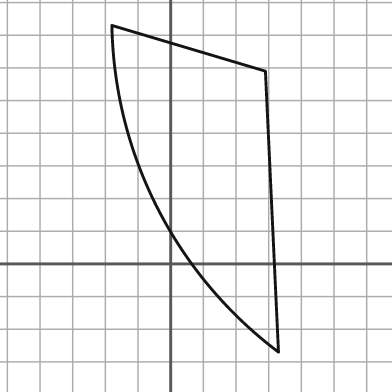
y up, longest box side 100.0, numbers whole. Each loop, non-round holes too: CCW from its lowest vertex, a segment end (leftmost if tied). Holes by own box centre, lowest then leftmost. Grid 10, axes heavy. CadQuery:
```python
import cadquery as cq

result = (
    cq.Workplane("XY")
    .moveTo(33.0, -27.0)
    .lineTo(29.0, 59.0)
    .lineTo(-18.0, 73.0)
    .threePointArc((-4.0, 17.0), (33.0, -27.0))
    .close()
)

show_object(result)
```